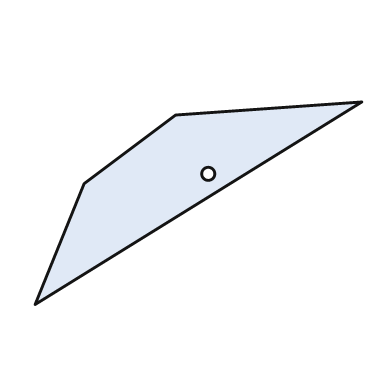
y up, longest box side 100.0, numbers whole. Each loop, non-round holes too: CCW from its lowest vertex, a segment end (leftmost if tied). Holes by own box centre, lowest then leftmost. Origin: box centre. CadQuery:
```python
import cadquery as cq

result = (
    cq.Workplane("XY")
    .moveTo(-50.0, -31.0)
    .lineTo(50.0, 31.0)
    .lineTo(-7.0, 27.0)
    .lineTo(-35.0, 6.0)
    .close()
    .moveTo(3.0, 9.0)
    .circle(2.0)
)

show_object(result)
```